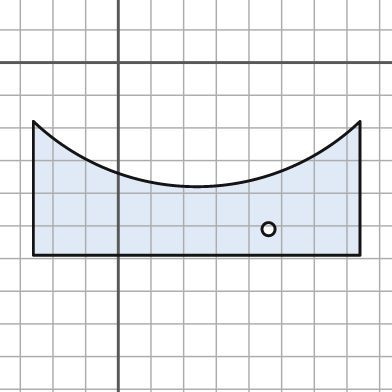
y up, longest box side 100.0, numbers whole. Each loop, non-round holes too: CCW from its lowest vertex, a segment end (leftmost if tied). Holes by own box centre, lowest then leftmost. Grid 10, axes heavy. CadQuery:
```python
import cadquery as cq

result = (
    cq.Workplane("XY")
    .moveTo(-26.0, -59.0)
    .lineTo(74.0, -59.0)
    .lineTo(74.0, -18.0)
    .threePointArc((24.0, -38.0), (-26.0, -18.0))
    .close()
    .moveTo(46.0, -51.0)
    .circle(2.0)
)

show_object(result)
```